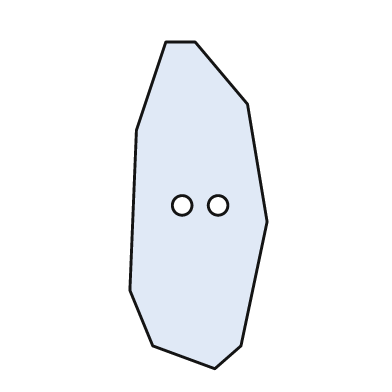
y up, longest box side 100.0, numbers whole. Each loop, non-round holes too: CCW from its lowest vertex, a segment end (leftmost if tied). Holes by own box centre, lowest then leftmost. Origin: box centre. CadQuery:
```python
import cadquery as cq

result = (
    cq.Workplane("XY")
    .moveTo(5.0, -50.0)
    .lineTo(13.0, -43.0)
    .lineTo(21.0, -5.0)
    .lineTo(15.0, 31.0)
    .lineTo(-1.0, 50.0)
    .lineTo(-10.0, 50.0)
    .lineTo(-19.0, 23.0)
    .lineTo(-21.0, -26.0)
    .lineTo(-14.0, -43.0)
    .close()
    .moveTo(-5.0, 0.0)
    .circle(3.0)
    .moveTo(6.0, 0.0)
    .circle(3.0)
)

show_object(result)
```